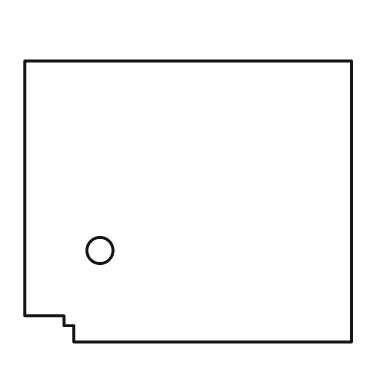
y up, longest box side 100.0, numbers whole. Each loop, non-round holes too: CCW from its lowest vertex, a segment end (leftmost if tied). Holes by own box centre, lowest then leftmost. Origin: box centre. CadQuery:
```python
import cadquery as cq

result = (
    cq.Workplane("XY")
    .moveTo(-35.0, -43.0)
    .lineTo(50.0, -43.0)
    .lineTo(50.0, 43.0)
    .lineTo(-50.0, 43.0)
    .lineTo(-50.0, -35.0)
    .lineTo(-38.0, -35.0)
    .lineTo(-38.0, -38.0)
    .lineTo(-35.0, -38.0)
    .close()
    .moveTo(-27.0, -15.0)
    .circle(4.0)
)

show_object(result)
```